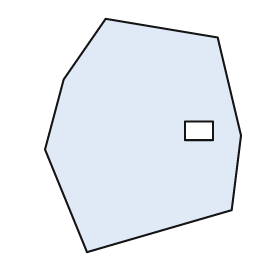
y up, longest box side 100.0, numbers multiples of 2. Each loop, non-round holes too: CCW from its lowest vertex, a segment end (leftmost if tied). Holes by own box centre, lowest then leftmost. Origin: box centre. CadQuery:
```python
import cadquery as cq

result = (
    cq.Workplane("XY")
    .moveTo(-24.0, -50.0)
    .lineTo(38.0, -32.0)
    .lineTo(42.0, 0.0)
    .lineTo(32.0, 42.0)
    .lineTo(-16.0, 50.0)
    .lineTo(-34.0, 24.0)
    .lineTo(-42.0, -6.0)
    .close()
    .moveTo(18.0, -2.0)
    .lineTo(30.0, -2.0)
    .lineTo(30.0, 6.0)
    .lineTo(18.0, 6.0)
    .close()
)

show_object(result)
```